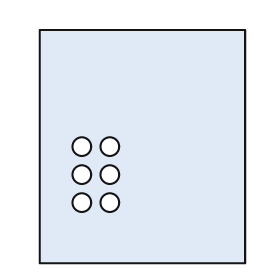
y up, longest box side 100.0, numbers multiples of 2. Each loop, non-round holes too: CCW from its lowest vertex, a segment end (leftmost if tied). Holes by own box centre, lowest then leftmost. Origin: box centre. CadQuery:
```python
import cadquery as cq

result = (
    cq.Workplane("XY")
    .moveTo(-44.0, -50.0)
    .lineTo(44.0, -50.0)
    .lineTo(44.0, 50.0)
    .lineTo(-44.0, 50.0)
    .close()
    .moveTo(-26.0, -24.0)
    .circle(4.0)
    .moveTo(-14.0, -24.0)
    .circle(4.0)
    .moveTo(-26.0, -12.0)
    .circle(4.0)
    .moveTo(-14.0, -12.0)
    .circle(4.0)
    .moveTo(-26.0, 0.0)
    .circle(4.0)
    .moveTo(-14.0, 0.0)
    .circle(4.0)
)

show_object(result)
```